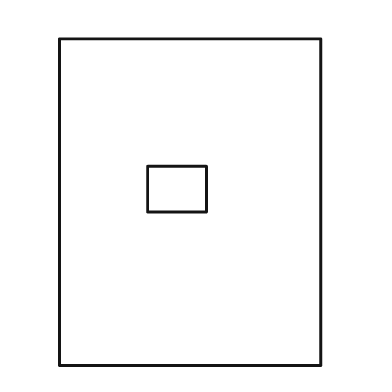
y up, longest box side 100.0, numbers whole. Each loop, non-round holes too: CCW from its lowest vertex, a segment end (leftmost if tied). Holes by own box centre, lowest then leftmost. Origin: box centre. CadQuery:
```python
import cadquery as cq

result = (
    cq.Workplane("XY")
    .moveTo(-40.0, -50.0)
    .lineTo(40.0, -50.0)
    .lineTo(40.0, 50.0)
    .lineTo(-40.0, 50.0)
    .close()
    .moveTo(-13.0, -3.0)
    .lineTo(5.0, -3.0)
    .lineTo(5.0, 11.0)
    .lineTo(-13.0, 11.0)
    .close()
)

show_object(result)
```